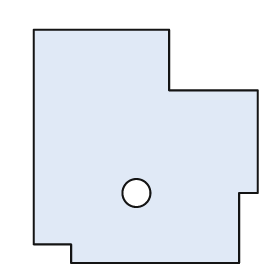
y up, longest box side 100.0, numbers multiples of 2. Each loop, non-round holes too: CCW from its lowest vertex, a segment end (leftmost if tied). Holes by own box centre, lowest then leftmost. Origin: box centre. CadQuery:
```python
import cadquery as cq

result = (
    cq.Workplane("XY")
    .moveTo(-32.0, -50.0)
    .lineTo(40.0, -50.0)
    .lineTo(40.0, -20.0)
    .lineTo(48.0, -20.0)
    .lineTo(48.0, 24.0)
    .lineTo(10.0, 24.0)
    .lineTo(10.0, 50.0)
    .lineTo(-48.0, 50.0)
    .lineTo(-48.0, -42.0)
    .lineTo(-32.0, -42.0)
    .close()
    .moveTo(-4.0, -20.0)
    .circle(6.0)
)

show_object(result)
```